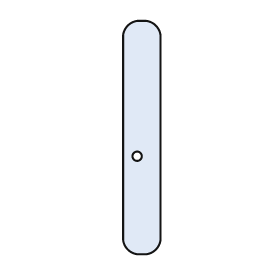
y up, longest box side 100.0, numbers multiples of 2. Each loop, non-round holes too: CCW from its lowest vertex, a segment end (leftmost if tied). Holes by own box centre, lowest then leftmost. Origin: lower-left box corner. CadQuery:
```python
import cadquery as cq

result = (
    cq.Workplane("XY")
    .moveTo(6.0, 0.0)
    .lineTo(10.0, 0.0)
    .threePointArc((14.0, 2.0), (16.0, 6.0))
    .lineTo(16.0, 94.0)
    .threePointArc((14.0, 98.0), (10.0, 100.0))
    .lineTo(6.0, 100.0)
    .threePointArc((2.0, 98.0), (0.0, 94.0))
    .lineTo(0.0, 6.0)
    .threePointArc((2.0, 2.0), (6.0, 0.0))
    .close()
    .moveTo(6.0, 42.0)
    .circle(2.0)
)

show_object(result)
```